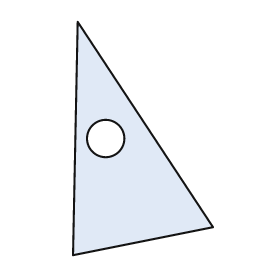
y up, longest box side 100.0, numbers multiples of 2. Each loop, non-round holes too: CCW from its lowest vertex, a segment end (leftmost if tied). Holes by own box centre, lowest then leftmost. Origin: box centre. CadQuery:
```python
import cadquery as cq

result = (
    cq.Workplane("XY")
    .moveTo(-30.0, -50.0)
    .lineTo(30.0, -38.0)
    .lineTo(-28.0, 50.0)
    .close()
    .moveTo(-16.0, 0.0)
    .circle(8.0)
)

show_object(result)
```